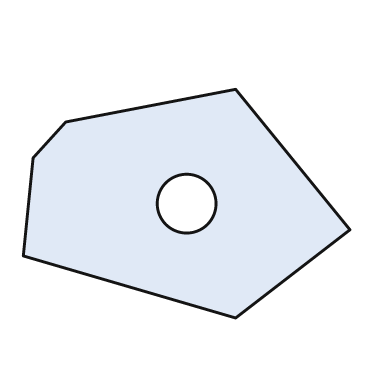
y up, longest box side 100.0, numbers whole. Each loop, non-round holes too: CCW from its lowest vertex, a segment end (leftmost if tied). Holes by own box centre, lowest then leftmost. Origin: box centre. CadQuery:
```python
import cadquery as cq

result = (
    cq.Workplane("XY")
    .moveTo(15.0, -35.0)
    .lineTo(50.0, -8.0)
    .lineTo(15.0, 35.0)
    .lineTo(-37.0, 25.0)
    .lineTo(-47.0, 14.0)
    .lineTo(-50.0, -16.0)
    .close()
    .moveTo(0.0, 0.0)
    .circle(9.0)
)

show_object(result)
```